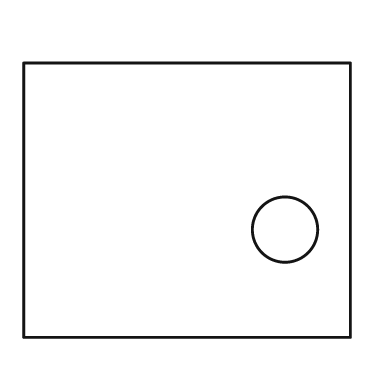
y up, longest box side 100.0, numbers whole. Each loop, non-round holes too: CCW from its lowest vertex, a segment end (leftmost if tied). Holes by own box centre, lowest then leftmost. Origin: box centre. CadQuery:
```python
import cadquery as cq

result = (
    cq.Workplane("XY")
    .moveTo(-50.0, -42.0)
    .lineTo(50.0, -42.0)
    .lineTo(50.0, 42.0)
    .lineTo(-50.0, 42.0)
    .close()
    .moveTo(30.0, -9.0)
    .circle(10.0)
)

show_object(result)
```